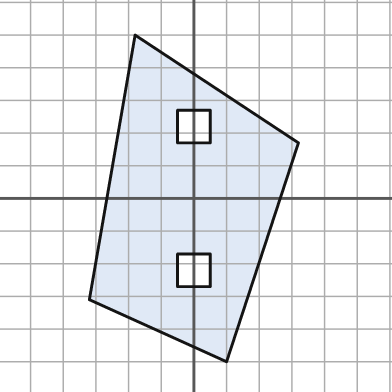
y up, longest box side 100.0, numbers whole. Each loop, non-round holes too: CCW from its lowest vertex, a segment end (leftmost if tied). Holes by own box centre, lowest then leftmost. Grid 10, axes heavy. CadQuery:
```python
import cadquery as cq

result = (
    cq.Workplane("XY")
    .moveTo(10.0, -50.0)
    .lineTo(32.0, 17.0)
    .lineTo(-18.0, 50.0)
    .lineTo(-32.0, -31.0)
    .close()
    .moveTo(-5.0, -27.0)
    .lineTo(5.0, -27.0)
    .lineTo(5.0, -17.0)
    .lineTo(-5.0, -17.0)
    .close()
    .moveTo(-5.0, 17.0)
    .lineTo(5.0, 17.0)
    .lineTo(5.0, 27.0)
    .lineTo(-5.0, 27.0)
    .close()
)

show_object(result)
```